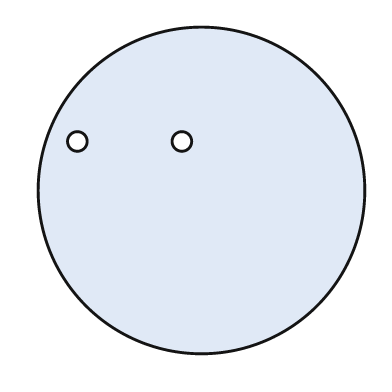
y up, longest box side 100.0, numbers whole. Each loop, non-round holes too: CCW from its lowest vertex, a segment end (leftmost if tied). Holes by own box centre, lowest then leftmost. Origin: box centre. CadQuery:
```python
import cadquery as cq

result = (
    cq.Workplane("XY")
    .moveTo(0.0, 0.0)
    .circle(50.0)
    .moveTo(-38.0, 15.0)
    .circle(3.0)
    .moveTo(-6.0, 15.0)
    .circle(3.0)
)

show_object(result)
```